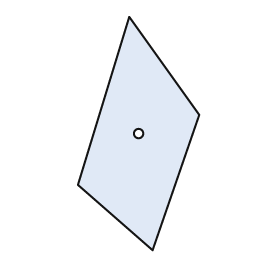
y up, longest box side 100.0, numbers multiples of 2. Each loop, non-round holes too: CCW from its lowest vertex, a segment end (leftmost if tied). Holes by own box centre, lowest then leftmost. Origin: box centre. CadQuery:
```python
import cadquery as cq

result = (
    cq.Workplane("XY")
    .moveTo(6.0, -50.0)
    .lineTo(26.0, 8.0)
    .lineTo(-4.0, 50.0)
    .lineTo(-26.0, -22.0)
    .close()
    .moveTo(0.0, 0.0)
    .circle(2.0)
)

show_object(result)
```